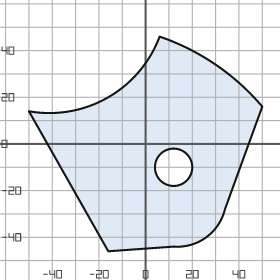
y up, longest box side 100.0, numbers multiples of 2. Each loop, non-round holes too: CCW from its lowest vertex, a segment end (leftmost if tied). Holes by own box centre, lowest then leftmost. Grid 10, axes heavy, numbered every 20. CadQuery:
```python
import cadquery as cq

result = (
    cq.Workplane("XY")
    .moveTo(-16.0, -46.0)
    .lineTo(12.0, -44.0)
    .threePointArc((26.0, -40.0), (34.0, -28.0))
    .lineTo(50.0, 16.0)
    .threePointArc((30.0, 34.0), (6.0, 46.0))
    .threePointArc((-16.0, 20.0), (-50.0, 14.0))
    .close()
    .moveTo(12.0, -10.0)
    .circle(8.0)
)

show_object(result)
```